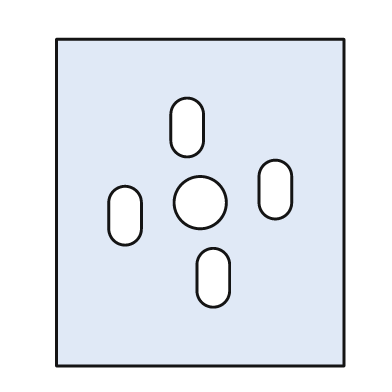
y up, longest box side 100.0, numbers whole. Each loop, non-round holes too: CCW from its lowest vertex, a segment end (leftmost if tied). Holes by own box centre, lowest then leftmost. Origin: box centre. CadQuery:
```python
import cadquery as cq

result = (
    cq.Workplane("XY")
    .moveTo(-44.0, -50.0)
    .lineTo(44.0, -50.0)
    .lineTo(44.0, 50.0)
    .lineTo(-44.0, 50.0)
    .close()
    .moveTo(-1.0, -27.0)
    .threePointArc((4.0, -32.0), (9.0, -27.0))
    .lineTo(9.0, -19.0)
    .threePointArc((4.0, -14.0), (-1.0, -19.0))
    .close()
    .moveTo(-28.0, -8.0)
    .threePointArc((-23.0, -13.0), (-18.0, -8.0))
    .lineTo(-18.0, 0.0)
    .threePointArc((-23.0, 5.0), (-28.0, 0.0))
    .close()
    .moveTo(0.0, 0.0)
    .circle(8.0)
    .moveTo(18.0, 0.0)
    .threePointArc((23.0, -5.0), (28.0, 0.0))
    .lineTo(28.0, 8.0)
    .threePointArc((23.0, 13.0), (18.0, 8.0))
    .close()
    .moveTo(-9.0, 19.0)
    .threePointArc((-4.0, 14.0), (1.0, 19.0))
    .lineTo(1.0, 27.0)
    .threePointArc((-4.0, 32.0), (-9.0, 27.0))
    .close()
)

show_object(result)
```